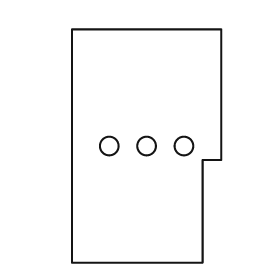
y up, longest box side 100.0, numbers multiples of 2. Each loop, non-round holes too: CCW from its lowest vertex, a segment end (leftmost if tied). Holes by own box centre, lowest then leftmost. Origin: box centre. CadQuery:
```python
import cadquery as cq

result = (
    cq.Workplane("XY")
    .moveTo(-32.0, -50.0)
    .lineTo(24.0, -50.0)
    .lineTo(24.0, -6.0)
    .lineTo(32.0, -6.0)
    .lineTo(32.0, 50.0)
    .lineTo(-32.0, 50.0)
    .close()
    .moveTo(-16.0, 0.0)
    .circle(4.0)
    .moveTo(0.0, 0.0)
    .circle(4.0)
    .moveTo(16.0, 0.0)
    .circle(4.0)
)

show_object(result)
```